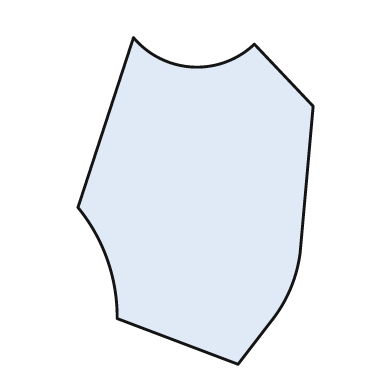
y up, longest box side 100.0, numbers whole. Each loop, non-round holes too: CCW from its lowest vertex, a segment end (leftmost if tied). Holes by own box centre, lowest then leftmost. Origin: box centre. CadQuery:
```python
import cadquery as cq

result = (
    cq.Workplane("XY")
    .moveTo(13.0, -50.0)
    .lineTo(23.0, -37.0)
    .threePointArc((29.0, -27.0), (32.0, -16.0))
    .lineTo(36.0, 29.0)
    .lineTo(18.0, 48.0)
    .threePointArc((-1.0, 41.0), (-19.0, 50.0))
    .lineTo(-36.0, -2.0)
    .threePointArc((-27.0, -18.0), (-24.0, -36.0))
    .close()
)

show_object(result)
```